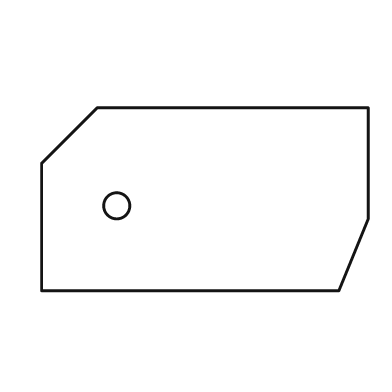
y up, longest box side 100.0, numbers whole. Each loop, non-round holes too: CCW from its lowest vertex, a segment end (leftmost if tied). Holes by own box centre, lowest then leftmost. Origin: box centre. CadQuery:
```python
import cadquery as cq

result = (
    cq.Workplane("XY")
    .moveTo(-50.0, -28.0)
    .lineTo(41.0, -28.0)
    .lineTo(50.0, -6.0)
    .lineTo(50.0, 28.0)
    .lineTo(-33.0, 28.0)
    .lineTo(-50.0, 11.0)
    .close()
    .moveTo(-27.0, -2.0)
    .circle(4.0)
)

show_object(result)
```